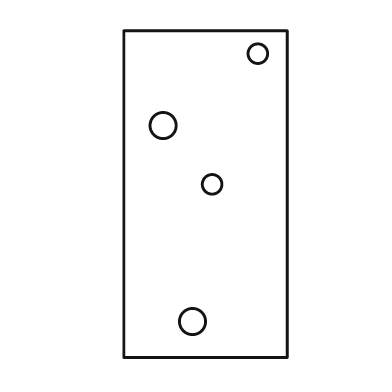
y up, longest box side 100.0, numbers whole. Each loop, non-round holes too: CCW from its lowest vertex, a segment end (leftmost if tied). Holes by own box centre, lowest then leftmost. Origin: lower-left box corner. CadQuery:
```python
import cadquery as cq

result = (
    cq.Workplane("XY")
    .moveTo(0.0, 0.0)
    .lineTo(50.0, 0.0)
    .lineTo(50.0, 100.0)
    .lineTo(0.0, 100.0)
    .close()
    .moveTo(21.0, 11.0)
    .circle(4.0)
    .moveTo(27.0, 53.0)
    .circle(3.0)
    .moveTo(12.0, 71.0)
    .circle(4.0)
    .moveTo(41.0, 93.0)
    .circle(3.0)
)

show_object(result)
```